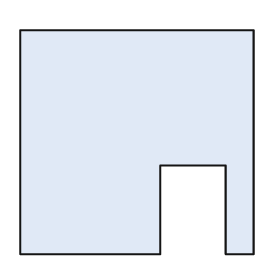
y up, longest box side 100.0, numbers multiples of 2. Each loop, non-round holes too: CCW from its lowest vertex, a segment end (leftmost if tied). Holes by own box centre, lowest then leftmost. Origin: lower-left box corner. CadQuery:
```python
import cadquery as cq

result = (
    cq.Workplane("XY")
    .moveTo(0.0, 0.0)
    .lineTo(60.0, 0.0)
    .lineTo(60.0, 38.0)
    .lineTo(88.0, 38.0)
    .lineTo(88.0, 0.0)
    .lineTo(100.0, 0.0)
    .lineTo(100.0, 96.0)
    .lineTo(0.0, 96.0)
    .close()
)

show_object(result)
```